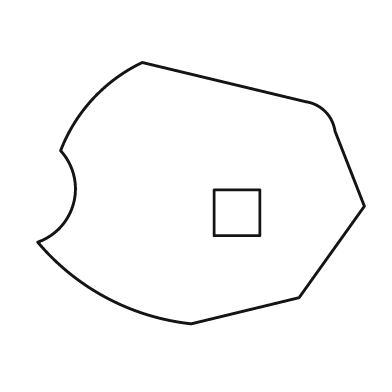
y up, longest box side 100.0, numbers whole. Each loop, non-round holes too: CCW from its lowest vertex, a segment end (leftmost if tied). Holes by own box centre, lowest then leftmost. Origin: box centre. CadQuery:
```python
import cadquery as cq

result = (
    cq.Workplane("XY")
    .moveTo(-3.0, -40.0)
    .lineTo(30.0, -32.0)
    .lineTo(50.0, -4.0)
    .lineTo(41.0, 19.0)
    .threePointArc((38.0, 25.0), (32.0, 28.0))
    .lineTo(-18.0, 40.0)
    .threePointArc((-33.0, 29.0), (-43.0, 13.0))
    .threePointArc((-39.0, -3.0), (-50.0, -15.0))
    .threePointArc((-29.0, -32.0), (-3.0, -40.0))
    .close()
    .moveTo(4.0, -13.0)
    .lineTo(18.0, -13.0)
    .lineTo(18.0, 1.0)
    .lineTo(4.0, 1.0)
    .close()
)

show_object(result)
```